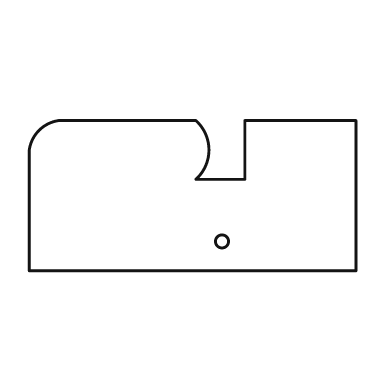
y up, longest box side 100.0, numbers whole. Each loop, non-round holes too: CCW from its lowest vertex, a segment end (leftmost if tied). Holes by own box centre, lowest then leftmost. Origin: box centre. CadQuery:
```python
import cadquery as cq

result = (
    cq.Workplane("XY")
    .moveTo(-50.0, -23.0)
    .lineTo(50.0, -23.0)
    .lineTo(50.0, 23.0)
    .lineTo(16.0, 23.0)
    .lineTo(16.0, 5.0)
    .lineTo(1.0, 5.0)
    .threePointArc((5.0, 14.0), (1.0, 23.0))
    .lineTo(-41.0, 23.0)
    .threePointArc((-47.0, 20.0), (-50.0, 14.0))
    .close()
    .moveTo(9.0, -14.0)
    .circle(2.0)
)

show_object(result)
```